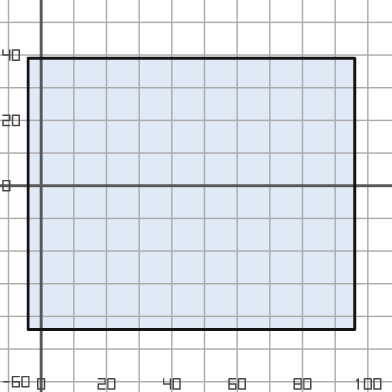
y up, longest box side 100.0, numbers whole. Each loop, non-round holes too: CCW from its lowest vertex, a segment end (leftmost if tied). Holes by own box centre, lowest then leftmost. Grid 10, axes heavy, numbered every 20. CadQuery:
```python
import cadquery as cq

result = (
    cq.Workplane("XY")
    .moveTo(-4.0, -44.0)
    .lineTo(96.0, -44.0)
    .lineTo(96.0, 39.0)
    .lineTo(-4.0, 39.0)
    .close()
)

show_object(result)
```